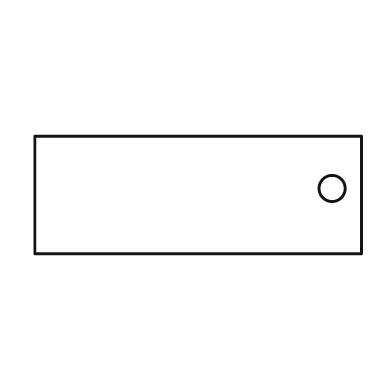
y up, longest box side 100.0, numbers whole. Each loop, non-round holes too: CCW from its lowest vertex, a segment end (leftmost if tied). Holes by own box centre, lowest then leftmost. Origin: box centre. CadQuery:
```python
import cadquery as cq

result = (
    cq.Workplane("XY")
    .moveTo(-50.0, -18.0)
    .lineTo(50.0, -18.0)
    .lineTo(50.0, 18.0)
    .lineTo(-50.0, 18.0)
    .close()
    .moveTo(41.0, 2.0)
    .circle(4.0)
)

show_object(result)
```